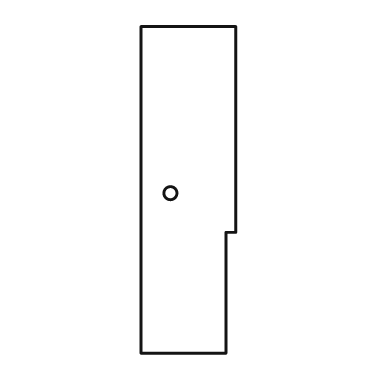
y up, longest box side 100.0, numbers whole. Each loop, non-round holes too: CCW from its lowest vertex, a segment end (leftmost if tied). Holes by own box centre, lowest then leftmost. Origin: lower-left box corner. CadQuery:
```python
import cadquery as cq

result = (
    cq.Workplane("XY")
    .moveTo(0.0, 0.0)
    .lineTo(26.0, 0.0)
    .lineTo(26.0, 37.0)
    .lineTo(29.0, 37.0)
    .lineTo(29.0, 100.0)
    .lineTo(0.0, 100.0)
    .close()
    .moveTo(9.0, 49.0)
    .circle(2.0)
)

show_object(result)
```